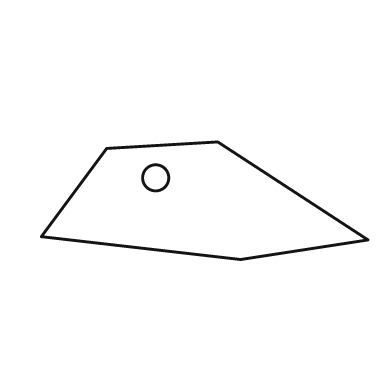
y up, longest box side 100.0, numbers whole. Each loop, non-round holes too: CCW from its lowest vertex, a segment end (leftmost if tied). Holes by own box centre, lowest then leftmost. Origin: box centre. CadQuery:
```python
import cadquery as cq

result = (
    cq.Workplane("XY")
    .moveTo(11.0, -18.0)
    .lineTo(50.0, -12.0)
    .lineTo(4.0, 18.0)
    .lineTo(-30.0, 16.0)
    .lineTo(-50.0, -11.0)
    .close()
    .moveTo(-15.0, 7.0)
    .circle(4.0)
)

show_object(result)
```